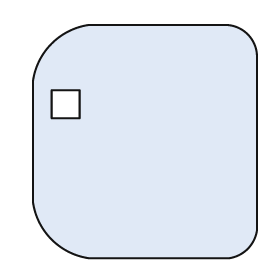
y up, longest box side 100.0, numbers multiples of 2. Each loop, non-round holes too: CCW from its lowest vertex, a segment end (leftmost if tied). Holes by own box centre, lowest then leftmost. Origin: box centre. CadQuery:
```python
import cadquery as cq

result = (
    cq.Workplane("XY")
    .moveTo(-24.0, -50.0)
    .lineTo(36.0, -50.0)
    .threePointArc((44.0, -46.0), (48.0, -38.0))
    .lineTo(48.0, 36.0)
    .threePointArc((44.0, 46.0), (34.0, 50.0))
    .lineTo(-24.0, 50.0)
    .threePointArc((-40.0, 42.0), (-48.0, 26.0))
    .lineTo(-48.0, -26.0)
    .threePointArc((-40.0, -42.0), (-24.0, -50.0))
    .close()
    .moveTo(-40.0, 10.0)
    .lineTo(-28.0, 10.0)
    .lineTo(-28.0, 22.0)
    .lineTo(-40.0, 22.0)
    .close()
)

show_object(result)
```